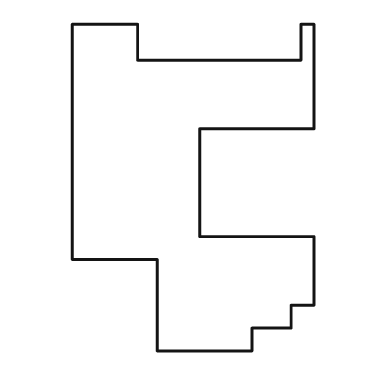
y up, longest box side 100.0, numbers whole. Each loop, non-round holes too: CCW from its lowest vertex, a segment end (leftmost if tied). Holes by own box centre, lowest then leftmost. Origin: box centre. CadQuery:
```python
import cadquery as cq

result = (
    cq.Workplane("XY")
    .moveTo(-11.0, -50.0)
    .lineTo(18.0, -50.0)
    .lineTo(18.0, -43.0)
    .lineTo(30.0, -43.0)
    .lineTo(30.0, -36.0)
    .lineTo(37.0, -36.0)
    .lineTo(37.0, -15.0)
    .lineTo(2.0, -15.0)
    .lineTo(2.0, 18.0)
    .lineTo(37.0, 18.0)
    .lineTo(37.0, 50.0)
    .lineTo(33.0, 50.0)
    .lineTo(33.0, 39.0)
    .lineTo(-17.0, 39.0)
    .lineTo(-17.0, 50.0)
    .lineTo(-37.0, 50.0)
    .lineTo(-37.0, -22.0)
    .lineTo(-11.0, -22.0)
    .close()
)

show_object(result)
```